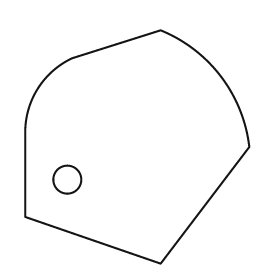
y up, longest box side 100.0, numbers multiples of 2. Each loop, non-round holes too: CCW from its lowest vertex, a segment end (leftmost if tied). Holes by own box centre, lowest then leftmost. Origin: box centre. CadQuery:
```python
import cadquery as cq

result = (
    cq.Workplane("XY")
    .moveTo(10.0, -50.0)
    .lineTo(48.0, 0.0)
    .threePointArc((36.0, 30.0), (10.0, 50.0))
    .lineTo(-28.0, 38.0)
    .threePointArc((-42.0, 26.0), (-48.0, 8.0))
    .lineTo(-48.0, -30.0)
    .close()
    .moveTo(-30.0, -14.0)
    .circle(6.0)
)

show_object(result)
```